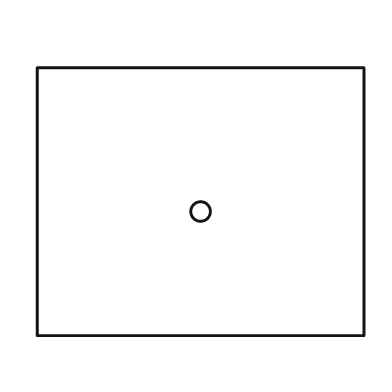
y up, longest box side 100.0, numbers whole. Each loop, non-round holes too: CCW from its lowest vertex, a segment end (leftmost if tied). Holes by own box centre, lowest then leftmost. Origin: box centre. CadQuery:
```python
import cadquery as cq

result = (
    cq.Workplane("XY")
    .moveTo(-50.0, -41.0)
    .lineTo(50.0, -41.0)
    .lineTo(50.0, 41.0)
    .lineTo(-50.0, 41.0)
    .close()
    .moveTo(0.0, -3.0)
    .circle(3.0)
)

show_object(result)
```